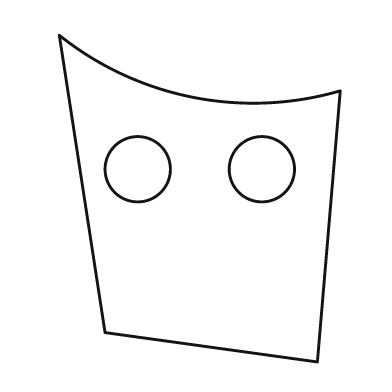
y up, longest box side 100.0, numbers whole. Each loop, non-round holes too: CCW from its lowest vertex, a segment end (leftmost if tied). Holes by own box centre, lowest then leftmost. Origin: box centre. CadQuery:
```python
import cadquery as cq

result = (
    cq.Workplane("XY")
    .moveTo(36.0, -50.0)
    .lineTo(43.0, 33.0)
    .threePointArc((-2.0, 31.0), (-43.0, 50.0))
    .lineTo(-29.0, -41.0)
    .close()
    .moveTo(-19.0, 9.0)
    .circle(10.0)
    .moveTo(19.0, 9.0)
    .circle(10.0)
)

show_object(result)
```